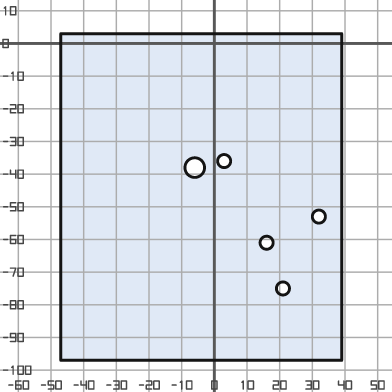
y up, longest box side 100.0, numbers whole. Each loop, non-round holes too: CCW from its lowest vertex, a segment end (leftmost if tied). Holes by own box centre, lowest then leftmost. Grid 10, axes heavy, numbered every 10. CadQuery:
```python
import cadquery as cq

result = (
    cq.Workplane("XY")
    .moveTo(-47.0, -97.0)
    .lineTo(39.0, -97.0)
    .lineTo(39.0, 3.0)
    .lineTo(-47.0, 3.0)
    .close()
    .moveTo(21.0, -75.0)
    .circle(2.0)
    .moveTo(16.0, -61.0)
    .circle(2.0)
    .moveTo(32.0, -53.0)
    .circle(2.0)
    .moveTo(-6.0, -38.0)
    .circle(3.0)
    .moveTo(3.0, -36.0)
    .circle(2.0)
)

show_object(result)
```